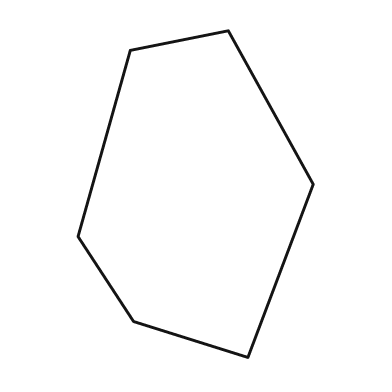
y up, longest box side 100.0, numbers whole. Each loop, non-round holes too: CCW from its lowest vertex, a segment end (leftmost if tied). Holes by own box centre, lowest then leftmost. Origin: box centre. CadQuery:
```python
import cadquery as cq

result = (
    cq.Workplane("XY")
    .moveTo(16.0, -50.0)
    .lineTo(36.0, 3.0)
    .lineTo(10.0, 50.0)
    .lineTo(-20.0, 44.0)
    .lineTo(-36.0, -13.0)
    .lineTo(-19.0, -39.0)
    .close()
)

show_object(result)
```